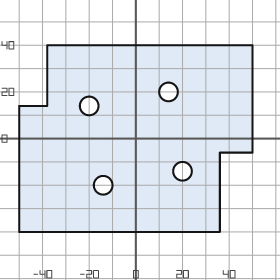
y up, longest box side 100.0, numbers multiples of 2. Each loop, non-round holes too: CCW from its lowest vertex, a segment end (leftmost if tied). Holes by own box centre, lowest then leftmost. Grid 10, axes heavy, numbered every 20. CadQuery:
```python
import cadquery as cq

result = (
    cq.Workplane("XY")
    .moveTo(-50.0, -40.0)
    .lineTo(36.0, -40.0)
    .lineTo(36.0, -6.0)
    .lineTo(50.0, -6.0)
    .lineTo(50.0, 40.0)
    .lineTo(-38.0, 40.0)
    .lineTo(-38.0, 14.0)
    .lineTo(-50.0, 14.0)
    .close()
    .moveTo(-14.0, -20.0)
    .circle(4.0)
    .moveTo(20.0, -14.0)
    .circle(4.0)
    .moveTo(-20.0, 14.0)
    .circle(4.0)
    .moveTo(14.0, 20.0)
    .circle(4.0)
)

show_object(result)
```